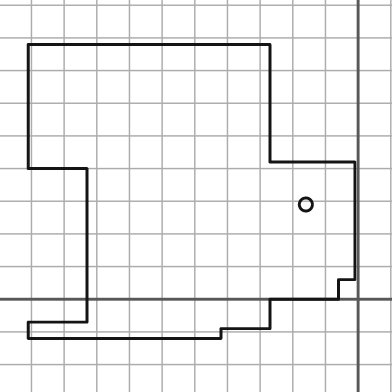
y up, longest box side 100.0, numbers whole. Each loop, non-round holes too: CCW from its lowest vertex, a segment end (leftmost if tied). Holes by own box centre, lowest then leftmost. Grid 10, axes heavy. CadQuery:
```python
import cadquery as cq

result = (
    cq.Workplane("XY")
    .moveTo(-101.0, -12.0)
    .lineTo(-42.0, -12.0)
    .lineTo(-42.0, -9.0)
    .lineTo(-27.0, -9.0)
    .lineTo(-27.0, 0.0)
    .lineTo(-6.0, 0.0)
    .lineTo(-6.0, 6.0)
    .lineTo(-1.0, 6.0)
    .lineTo(-1.0, 42.0)
    .lineTo(-27.0, 42.0)
    .lineTo(-27.0, 78.0)
    .lineTo(-101.0, 78.0)
    .lineTo(-101.0, 40.0)
    .lineTo(-83.0, 40.0)
    .lineTo(-83.0, -7.0)
    .lineTo(-101.0, -7.0)
    .close()
    .moveTo(-16.0, 29.0)
    .circle(2.0)
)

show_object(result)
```